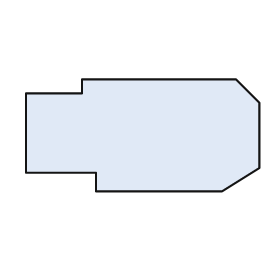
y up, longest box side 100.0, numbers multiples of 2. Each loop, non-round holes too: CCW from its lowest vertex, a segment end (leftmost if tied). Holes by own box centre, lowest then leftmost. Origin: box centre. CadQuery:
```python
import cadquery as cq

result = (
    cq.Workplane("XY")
    .moveTo(-20.0, -24.0)
    .lineTo(34.0, -24.0)
    .lineTo(50.0, -14.0)
    .lineTo(50.0, 14.0)
    .lineTo(40.0, 24.0)
    .lineTo(-26.0, 24.0)
    .lineTo(-26.0, 18.0)
    .lineTo(-50.0, 18.0)
    .lineTo(-50.0, -16.0)
    .lineTo(-20.0, -16.0)
    .close()
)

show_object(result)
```